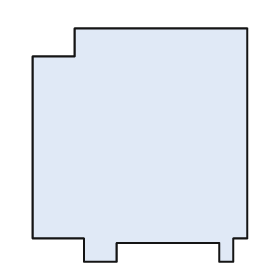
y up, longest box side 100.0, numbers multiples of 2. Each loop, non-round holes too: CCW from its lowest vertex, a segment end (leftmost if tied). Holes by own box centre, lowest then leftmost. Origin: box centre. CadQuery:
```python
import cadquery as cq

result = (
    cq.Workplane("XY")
    .moveTo(-24.0, -50.0)
    .lineTo(-10.0, -50.0)
    .lineTo(-10.0, -42.0)
    .lineTo(34.0, -42.0)
    .lineTo(34.0, -50.0)
    .lineTo(40.0, -50.0)
    .lineTo(40.0, -40.0)
    .lineTo(46.0, -40.0)
    .lineTo(46.0, 50.0)
    .lineTo(-28.0, 50.0)
    .lineTo(-28.0, 38.0)
    .lineTo(-46.0, 38.0)
    .lineTo(-46.0, -40.0)
    .lineTo(-24.0, -40.0)
    .close()
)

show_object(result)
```